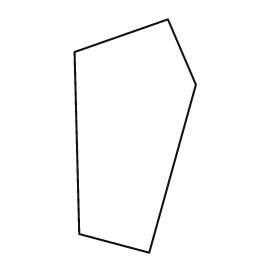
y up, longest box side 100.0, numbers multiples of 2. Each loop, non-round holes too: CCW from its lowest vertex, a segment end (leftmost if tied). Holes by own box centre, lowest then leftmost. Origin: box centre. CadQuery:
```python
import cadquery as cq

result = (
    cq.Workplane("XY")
    .moveTo(6.0, -50.0)
    .lineTo(26.0, 22.0)
    .lineTo(14.0, 50.0)
    .lineTo(-26.0, 36.0)
    .lineTo(-24.0, -42.0)
    .close()
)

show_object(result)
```